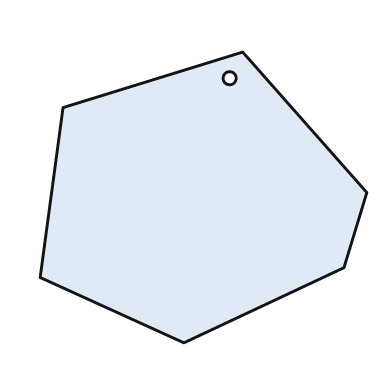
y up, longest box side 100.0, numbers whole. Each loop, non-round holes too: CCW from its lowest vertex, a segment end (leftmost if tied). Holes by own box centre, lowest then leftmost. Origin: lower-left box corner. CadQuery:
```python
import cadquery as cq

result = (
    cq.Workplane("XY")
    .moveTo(44.0, 0.0)
    .lineTo(93.0, 23.0)
    .lineTo(100.0, 46.0)
    .lineTo(62.0, 89.0)
    .lineTo(7.0, 72.0)
    .lineTo(0.0, 20.0)
    .close()
    .moveTo(58.0, 81.0)
    .circle(2.0)
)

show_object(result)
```